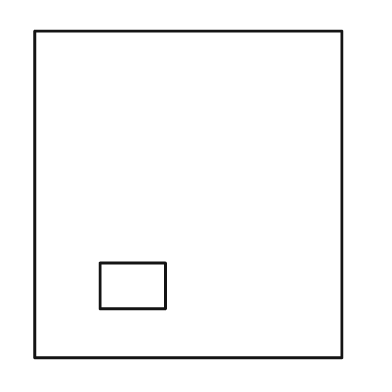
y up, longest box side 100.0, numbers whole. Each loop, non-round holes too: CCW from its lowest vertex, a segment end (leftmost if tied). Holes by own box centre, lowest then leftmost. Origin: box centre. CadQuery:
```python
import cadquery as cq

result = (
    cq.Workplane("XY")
    .moveTo(-47.0, -50.0)
    .lineTo(47.0, -50.0)
    .lineTo(47.0, 50.0)
    .lineTo(-47.0, 50.0)
    .close()
    .moveTo(-27.0, -35.0)
    .lineTo(-7.0, -35.0)
    .lineTo(-7.0, -21.0)
    .lineTo(-27.0, -21.0)
    .close()
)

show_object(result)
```